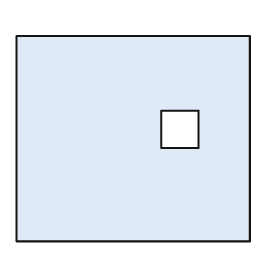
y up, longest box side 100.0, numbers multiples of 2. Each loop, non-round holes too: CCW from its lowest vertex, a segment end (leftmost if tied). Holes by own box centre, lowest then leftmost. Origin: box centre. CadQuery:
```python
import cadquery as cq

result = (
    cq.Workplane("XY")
    .moveTo(-50.0, -44.0)
    .lineTo(50.0, -44.0)
    .lineTo(50.0, 44.0)
    .lineTo(-50.0, 44.0)
    .close()
    .moveTo(12.0, -4.0)
    .lineTo(28.0, -4.0)
    .lineTo(28.0, 12.0)
    .lineTo(12.0, 12.0)
    .close()
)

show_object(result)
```